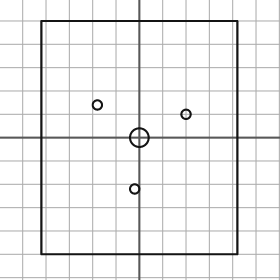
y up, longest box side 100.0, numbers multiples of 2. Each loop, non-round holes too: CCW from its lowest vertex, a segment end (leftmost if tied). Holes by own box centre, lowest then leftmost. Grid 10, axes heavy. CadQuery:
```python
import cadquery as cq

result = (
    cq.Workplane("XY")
    .moveTo(-42.0, -50.0)
    .lineTo(42.0, -50.0)
    .lineTo(42.0, 50.0)
    .lineTo(-42.0, 50.0)
    .close()
    .moveTo(-2.0, -22.0)
    .circle(2.0)
    .moveTo(0.0, 0.0)
    .circle(4.0)
    .moveTo(20.0, 10.0)
    .circle(2.0)
    .moveTo(-18.0, 14.0)
    .circle(2.0)
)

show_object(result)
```